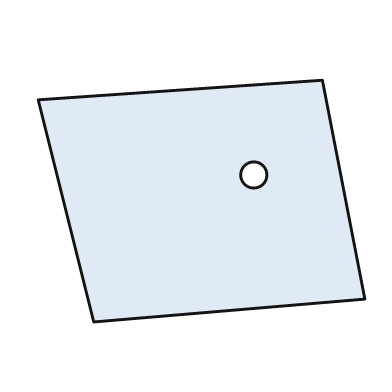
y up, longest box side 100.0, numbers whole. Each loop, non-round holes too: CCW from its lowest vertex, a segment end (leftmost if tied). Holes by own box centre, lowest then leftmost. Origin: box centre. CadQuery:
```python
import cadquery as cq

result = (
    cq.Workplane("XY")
    .moveTo(-33.0, -37.0)
    .lineTo(50.0, -30.0)
    .lineTo(37.0, 37.0)
    .lineTo(-50.0, 31.0)
    .close()
    .moveTo(16.0, 8.0)
    .circle(4.0)
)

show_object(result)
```